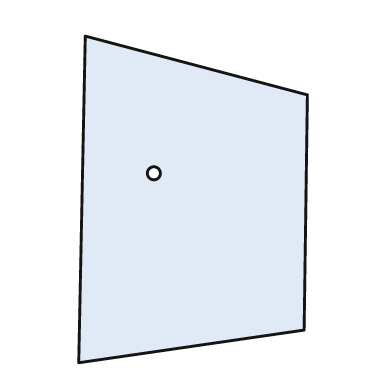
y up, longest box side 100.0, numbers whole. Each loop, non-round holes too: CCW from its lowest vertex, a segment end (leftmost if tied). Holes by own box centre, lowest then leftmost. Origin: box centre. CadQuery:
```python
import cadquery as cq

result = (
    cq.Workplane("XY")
    .moveTo(-35.0, -50.0)
    .lineTo(34.0, -40.0)
    .lineTo(35.0, 32.0)
    .lineTo(-33.0, 50.0)
    .close()
    .moveTo(-12.0, 8.0)
    .circle(2.0)
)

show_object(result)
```